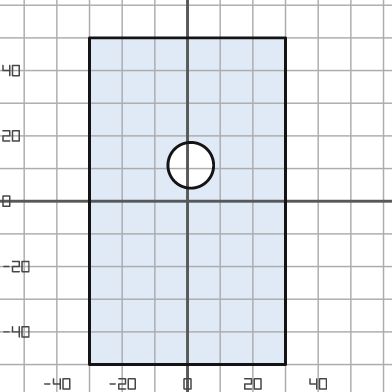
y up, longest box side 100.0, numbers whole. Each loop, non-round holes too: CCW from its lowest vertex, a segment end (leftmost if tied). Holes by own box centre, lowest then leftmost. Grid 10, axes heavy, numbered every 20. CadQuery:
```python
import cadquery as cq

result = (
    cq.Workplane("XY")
    .moveTo(-30.0, -50.0)
    .lineTo(30.0, -50.0)
    .lineTo(30.0, 50.0)
    .lineTo(-30.0, 50.0)
    .close()
    .moveTo(1.0, 11.0)
    .circle(7.0)
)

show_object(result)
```